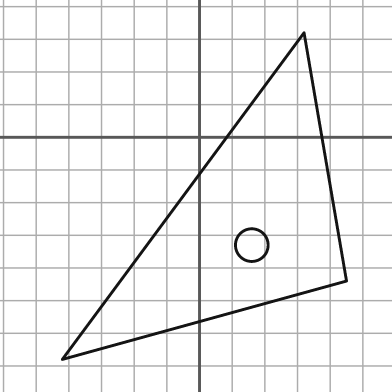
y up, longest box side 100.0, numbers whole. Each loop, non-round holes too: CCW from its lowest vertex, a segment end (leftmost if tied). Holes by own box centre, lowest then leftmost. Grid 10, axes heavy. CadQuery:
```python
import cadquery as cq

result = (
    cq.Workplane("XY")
    .moveTo(-42.0, -68.0)
    .lineTo(45.0, -44.0)
    .lineTo(32.0, 32.0)
    .close()
    .moveTo(16.0, -33.0)
    .circle(5.0)
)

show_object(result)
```